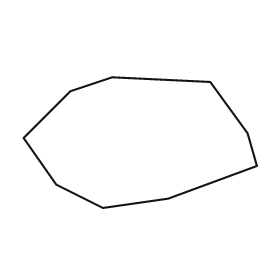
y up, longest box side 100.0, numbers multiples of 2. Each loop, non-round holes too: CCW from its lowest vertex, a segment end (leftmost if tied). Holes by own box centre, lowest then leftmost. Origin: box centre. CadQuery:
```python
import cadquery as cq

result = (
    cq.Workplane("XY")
    .moveTo(-16.0, -28.0)
    .lineTo(12.0, -24.0)
    .lineTo(50.0, -10.0)
    .lineTo(46.0, 4.0)
    .lineTo(30.0, 26.0)
    .lineTo(-12.0, 28.0)
    .lineTo(-30.0, 22.0)
    .lineTo(-50.0, 2.0)
    .lineTo(-36.0, -18.0)
    .close()
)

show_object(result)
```